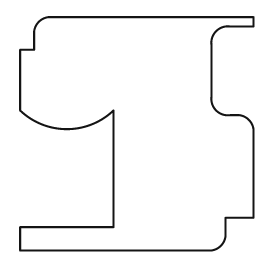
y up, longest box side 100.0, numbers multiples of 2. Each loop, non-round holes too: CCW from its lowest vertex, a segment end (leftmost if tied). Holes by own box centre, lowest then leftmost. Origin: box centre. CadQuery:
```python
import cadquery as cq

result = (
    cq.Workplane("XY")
    .moveTo(-50.0, -50.0)
    .lineTo(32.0, -50.0)
    .threePointArc((36.0, -48.0), (38.0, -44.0))
    .lineTo(38.0, -36.0)
    .lineTo(50.0, -36.0)
    .lineTo(50.0, 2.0)
    .threePointArc((48.0, 6.0), (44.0, 8.0))
    .lineTo(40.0, 8.0)
    .threePointArc((34.0, 10.0), (32.0, 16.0))
    .lineTo(32.0, 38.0)
    .threePointArc((34.0, 44.0), (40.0, 46.0))
    .lineTo(50.0, 46.0)
    .lineTo(50.0, 50.0)
    .lineTo(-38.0, 50.0)
    .threePointArc((-42.0, 48.0), (-44.0, 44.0))
    .lineTo(-44.0, 36.0)
    .lineTo(-50.0, 36.0)
    .lineTo(-50.0, 10.0)
    .threePointArc((-30.0, 2.0), (-10.0, 10.0))
    .lineTo(-10.0, -40.0)
    .lineTo(-50.0, -40.0)
    .close()
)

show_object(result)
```